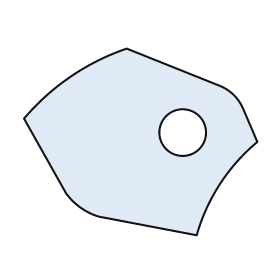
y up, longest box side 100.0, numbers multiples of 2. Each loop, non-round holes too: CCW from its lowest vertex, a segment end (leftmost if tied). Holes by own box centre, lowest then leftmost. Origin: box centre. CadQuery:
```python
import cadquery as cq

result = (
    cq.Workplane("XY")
    .moveTo(24.0, -40.0)
    .threePointArc((34.0, -18.0), (50.0, 0.0))
    .lineTo(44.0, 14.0)
    .threePointArc((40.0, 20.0), (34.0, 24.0))
    .lineTo(-6.0, 40.0)
    .threePointArc((-30.0, 28.0), (-50.0, 10.0))
    .lineTo(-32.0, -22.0)
    .threePointArc((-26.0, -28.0), (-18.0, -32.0))
    .close()
    .moveTo(18.0, 4.0)
    .circle(10.0)
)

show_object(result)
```